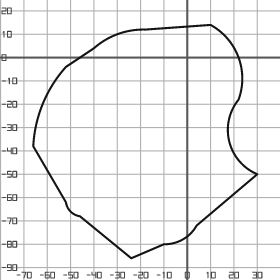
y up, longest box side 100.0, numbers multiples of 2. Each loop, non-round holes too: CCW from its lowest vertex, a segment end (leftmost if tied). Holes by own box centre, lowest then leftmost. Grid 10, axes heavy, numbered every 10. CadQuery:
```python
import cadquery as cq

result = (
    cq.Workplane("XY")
    .moveTo(-24.0, -86.0)
    .lineTo(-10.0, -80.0)
    .threePointArc((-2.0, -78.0), (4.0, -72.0))
    .lineTo(30.0, -50.0)
    .threePointArc((18.0, -36.0), (22.0, -18.0))
    .threePointArc((22.0, 0.0), (10.0, 14.0))
    .lineTo(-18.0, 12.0)
    .threePointArc((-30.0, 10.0), (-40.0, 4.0))
    .lineTo(-52.0, -4.0)
    .threePointArc((-62.0, -20.0), (-66.0, -38.0))
    .lineTo(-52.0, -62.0)
    .threePointArc((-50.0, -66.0), (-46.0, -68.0))
    .close()
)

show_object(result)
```